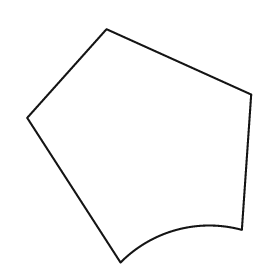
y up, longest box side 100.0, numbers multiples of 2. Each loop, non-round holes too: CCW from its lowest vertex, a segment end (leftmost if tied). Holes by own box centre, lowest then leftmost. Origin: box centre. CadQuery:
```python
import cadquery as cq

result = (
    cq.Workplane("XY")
    .moveTo(-8.0, -50.0)
    .threePointArc((16.0, -36.0), (44.0, -36.0))
    .lineTo(48.0, 22.0)
    .lineTo(-14.0, 50.0)
    .lineTo(-48.0, 12.0)
    .close()
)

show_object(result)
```